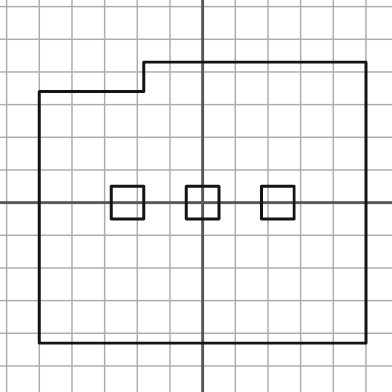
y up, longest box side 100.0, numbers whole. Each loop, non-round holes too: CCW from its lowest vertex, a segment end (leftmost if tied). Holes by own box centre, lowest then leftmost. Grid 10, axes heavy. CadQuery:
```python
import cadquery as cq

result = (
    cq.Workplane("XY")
    .moveTo(-50.0, -43.0)
    .lineTo(50.0, -43.0)
    .lineTo(50.0, 43.0)
    .lineTo(-18.0, 43.0)
    .lineTo(-18.0, 34.0)
    .lineTo(-50.0, 34.0)
    .close()
    .moveTo(-28.0, -5.0)
    .lineTo(-18.0, -5.0)
    .lineTo(-18.0, 5.0)
    .lineTo(-28.0, 5.0)
    .close()
    .moveTo(-5.0, -5.0)
    .lineTo(5.0, -5.0)
    .lineTo(5.0, 5.0)
    .lineTo(-5.0, 5.0)
    .close()
    .moveTo(18.0, -5.0)
    .lineTo(28.0, -5.0)
    .lineTo(28.0, 5.0)
    .lineTo(18.0, 5.0)
    .close()
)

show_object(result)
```